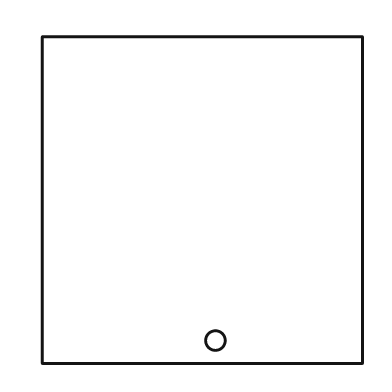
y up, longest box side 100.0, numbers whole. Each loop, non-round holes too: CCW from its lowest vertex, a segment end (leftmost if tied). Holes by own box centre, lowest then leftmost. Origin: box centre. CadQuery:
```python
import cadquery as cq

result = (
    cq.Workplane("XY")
    .moveTo(-49.0, -50.0)
    .lineTo(49.0, -50.0)
    .lineTo(49.0, 50.0)
    .lineTo(-49.0, 50.0)
    .close()
    .moveTo(4.0, -43.0)
    .circle(3.0)
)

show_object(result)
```